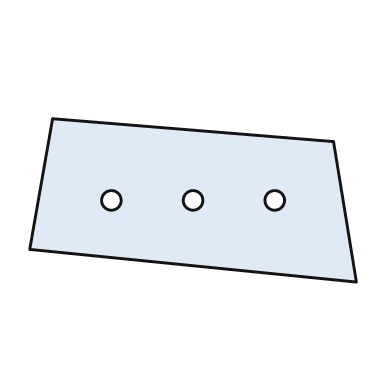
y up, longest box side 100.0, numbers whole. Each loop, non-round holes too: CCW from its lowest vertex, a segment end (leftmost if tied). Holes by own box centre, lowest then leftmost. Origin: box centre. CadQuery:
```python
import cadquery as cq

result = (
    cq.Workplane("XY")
    .moveTo(50.0, -25.0)
    .lineTo(43.0, 18.0)
    .lineTo(-43.0, 25.0)
    .lineTo(-50.0, -15.0)
    .close()
    .moveTo(-25.0, 0.0)
    .circle(3.0)
    .moveTo(0.0, 0.0)
    .circle(3.0)
    .moveTo(25.0, 0.0)
    .circle(3.0)
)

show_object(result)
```